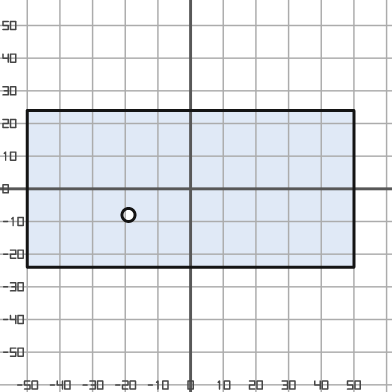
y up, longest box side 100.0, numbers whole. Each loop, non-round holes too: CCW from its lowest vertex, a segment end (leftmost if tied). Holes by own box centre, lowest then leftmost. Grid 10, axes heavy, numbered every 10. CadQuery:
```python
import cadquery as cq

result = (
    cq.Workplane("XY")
    .moveTo(-50.0, -24.0)
    .lineTo(50.0, -24.0)
    .lineTo(50.0, 24.0)
    .lineTo(-50.0, 24.0)
    .close()
    .moveTo(-19.0, -8.0)
    .circle(2.0)
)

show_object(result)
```